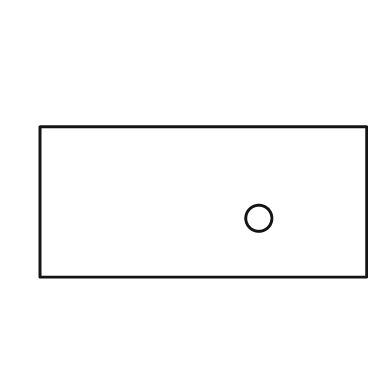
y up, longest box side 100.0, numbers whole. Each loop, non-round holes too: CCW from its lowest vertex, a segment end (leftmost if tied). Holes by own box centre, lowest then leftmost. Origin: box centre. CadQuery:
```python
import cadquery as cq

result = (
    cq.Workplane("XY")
    .moveTo(-50.0, -23.0)
    .lineTo(50.0, -23.0)
    .lineTo(50.0, 23.0)
    .lineTo(-50.0, 23.0)
    .close()
    .moveTo(17.0, -5.0)
    .circle(4.0)
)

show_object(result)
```